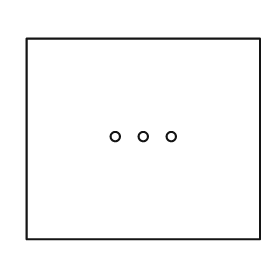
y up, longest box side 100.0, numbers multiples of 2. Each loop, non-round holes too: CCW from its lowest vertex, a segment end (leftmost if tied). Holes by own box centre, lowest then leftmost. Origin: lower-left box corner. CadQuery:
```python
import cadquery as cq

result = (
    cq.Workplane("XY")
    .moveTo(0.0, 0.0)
    .lineTo(100.0, 0.0)
    .lineTo(100.0, 86.0)
    .lineTo(0.0, 86.0)
    .close()
    .moveTo(38.0, 44.0)
    .circle(2.0)
    .moveTo(50.0, 44.0)
    .circle(2.0)
    .moveTo(62.0, 44.0)
    .circle(2.0)
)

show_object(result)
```